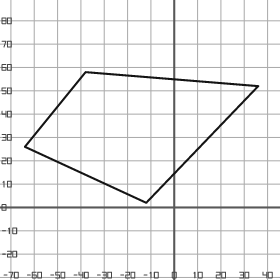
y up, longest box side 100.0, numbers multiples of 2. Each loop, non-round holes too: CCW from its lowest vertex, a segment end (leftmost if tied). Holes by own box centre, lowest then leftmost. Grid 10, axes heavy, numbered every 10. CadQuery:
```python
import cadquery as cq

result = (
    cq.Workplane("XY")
    .moveTo(-12.0, 2.0)
    .lineTo(36.0, 52.0)
    .lineTo(-38.0, 58.0)
    .lineTo(-64.0, 26.0)
    .close()
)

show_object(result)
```